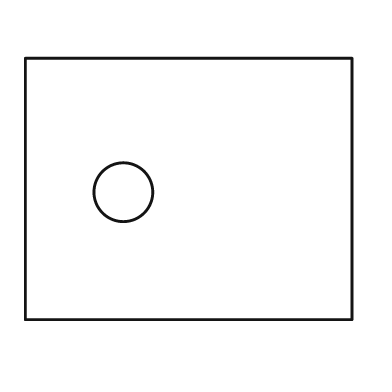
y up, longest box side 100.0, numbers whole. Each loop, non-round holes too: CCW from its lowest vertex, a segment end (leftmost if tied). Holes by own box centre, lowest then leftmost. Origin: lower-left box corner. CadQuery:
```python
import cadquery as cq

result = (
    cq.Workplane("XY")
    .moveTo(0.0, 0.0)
    .lineTo(100.0, 0.0)
    .lineTo(100.0, 80.0)
    .lineTo(0.0, 80.0)
    .close()
    .moveTo(30.0, 39.0)
    .circle(9.0)
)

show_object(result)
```